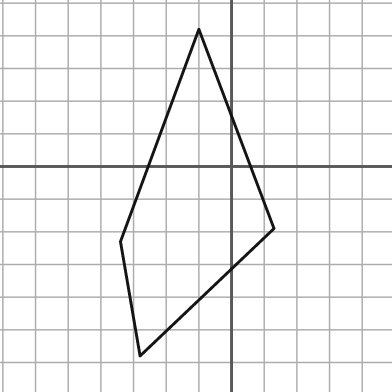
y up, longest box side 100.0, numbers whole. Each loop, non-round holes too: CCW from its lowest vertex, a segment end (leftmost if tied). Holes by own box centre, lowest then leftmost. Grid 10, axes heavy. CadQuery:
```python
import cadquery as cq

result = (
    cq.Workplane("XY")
    .moveTo(-28.0, -58.0)
    .lineTo(13.0, -19.0)
    .lineTo(-10.0, 42.0)
    .lineTo(-34.0, -23.0)
    .close()
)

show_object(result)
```